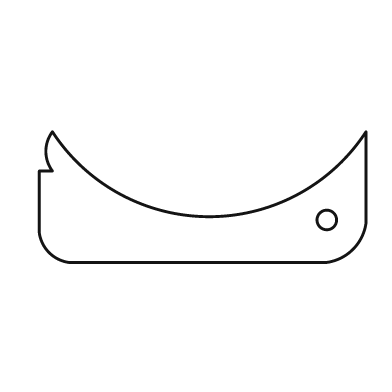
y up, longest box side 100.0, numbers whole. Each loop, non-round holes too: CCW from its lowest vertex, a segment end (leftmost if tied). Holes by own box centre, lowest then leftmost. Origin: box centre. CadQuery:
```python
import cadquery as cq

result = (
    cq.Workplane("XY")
    .moveTo(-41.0, -20.0)
    .lineTo(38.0, -20.0)
    .threePointArc((46.0, -16.0), (50.0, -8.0))
    .lineTo(50.0, 20.0)
    .threePointArc((2.0, -6.0), (-46.0, 20.0))
    .threePointArc((-48.0, 14.0), (-46.0, 8.0))
    .lineTo(-50.0, 8.0)
    .lineTo(-50.0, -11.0)
    .threePointArc((-47.0, -17.0), (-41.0, -20.0))
    .close()
    .moveTo(38.0, -7.0)
    .circle(3.0)
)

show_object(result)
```